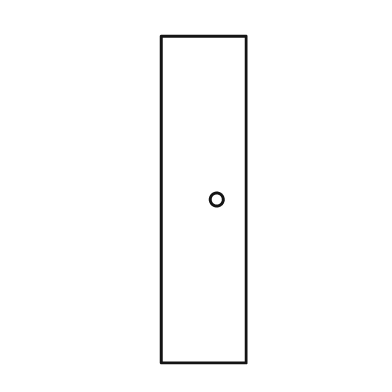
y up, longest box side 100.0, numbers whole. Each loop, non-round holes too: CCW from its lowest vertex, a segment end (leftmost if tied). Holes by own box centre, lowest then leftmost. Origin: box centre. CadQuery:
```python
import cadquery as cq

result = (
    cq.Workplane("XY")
    .moveTo(-13.0, -50.0)
    .lineTo(13.0, -50.0)
    .lineTo(13.0, 50.0)
    .lineTo(-13.0, 50.0)
    .close()
    .moveTo(4.0, 0.0)
    .circle(2.0)
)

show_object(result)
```